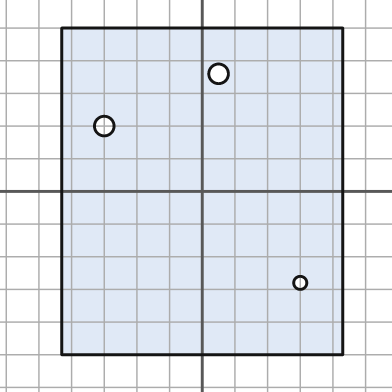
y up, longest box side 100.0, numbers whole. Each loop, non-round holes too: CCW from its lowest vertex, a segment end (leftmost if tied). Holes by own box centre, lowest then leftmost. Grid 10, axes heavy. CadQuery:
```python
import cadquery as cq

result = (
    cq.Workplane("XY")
    .moveTo(-43.0, -50.0)
    .lineTo(43.0, -50.0)
    .lineTo(43.0, 50.0)
    .lineTo(-43.0, 50.0)
    .close()
    .moveTo(30.0, -28.0)
    .circle(2.0)
    .moveTo(-30.0, 20.0)
    .circle(3.0)
    .moveTo(5.0, 36.0)
    .circle(3.0)
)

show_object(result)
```